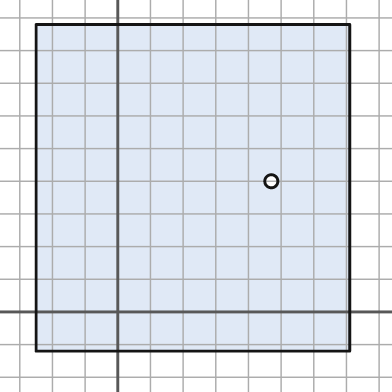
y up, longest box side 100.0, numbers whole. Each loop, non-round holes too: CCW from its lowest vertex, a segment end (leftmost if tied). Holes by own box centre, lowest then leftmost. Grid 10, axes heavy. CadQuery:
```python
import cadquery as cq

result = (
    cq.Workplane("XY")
    .moveTo(-25.0, -12.0)
    .lineTo(71.0, -12.0)
    .lineTo(71.0, 88.0)
    .lineTo(-25.0, 88.0)
    .close()
    .moveTo(47.0, 40.0)
    .circle(2.0)
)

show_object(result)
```